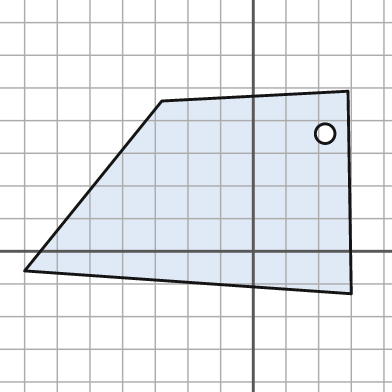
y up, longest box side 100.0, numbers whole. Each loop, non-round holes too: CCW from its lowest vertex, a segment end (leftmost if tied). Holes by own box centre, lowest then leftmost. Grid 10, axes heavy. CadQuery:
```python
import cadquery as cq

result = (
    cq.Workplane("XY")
    .moveTo(30.0, -13.0)
    .lineTo(29.0, 49.0)
    .lineTo(-28.0, 46.0)
    .lineTo(-70.0, -6.0)
    .close()
    .moveTo(22.0, 36.0)
    .circle(3.0)
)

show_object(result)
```